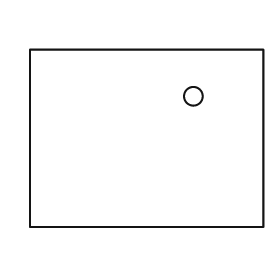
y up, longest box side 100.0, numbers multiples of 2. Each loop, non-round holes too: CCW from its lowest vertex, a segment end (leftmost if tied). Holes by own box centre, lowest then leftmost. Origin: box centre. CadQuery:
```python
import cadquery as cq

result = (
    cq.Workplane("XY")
    .moveTo(-50.0, -38.0)
    .lineTo(50.0, -38.0)
    .lineTo(50.0, 38.0)
    .lineTo(-50.0, 38.0)
    .close()
    .moveTo(20.0, 18.0)
    .circle(4.0)
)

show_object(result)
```